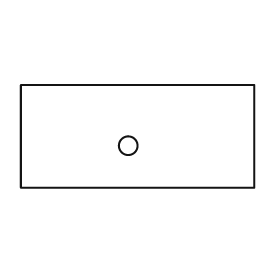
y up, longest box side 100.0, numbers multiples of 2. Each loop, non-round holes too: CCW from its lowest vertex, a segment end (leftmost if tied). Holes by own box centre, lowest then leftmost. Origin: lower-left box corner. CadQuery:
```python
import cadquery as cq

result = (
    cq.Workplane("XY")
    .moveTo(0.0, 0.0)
    .lineTo(100.0, 0.0)
    .lineTo(100.0, 44.0)
    .lineTo(0.0, 44.0)
    .close()
    .moveTo(46.0, 18.0)
    .circle(4.0)
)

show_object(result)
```